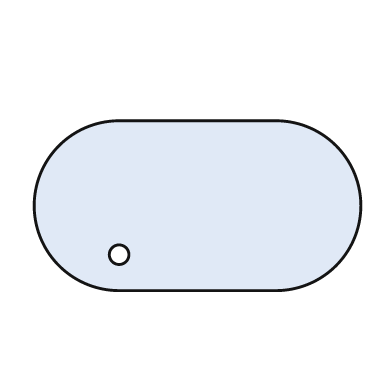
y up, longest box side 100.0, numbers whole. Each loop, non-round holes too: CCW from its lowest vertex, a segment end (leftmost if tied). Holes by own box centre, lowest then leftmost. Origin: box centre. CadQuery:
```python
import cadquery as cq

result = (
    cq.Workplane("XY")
    .moveTo(-24.0, -26.0)
    .lineTo(24.0, -26.0)
    .threePointArc((50.0, 0.0), (24.0, 26.0))
    .lineTo(-24.0, 26.0)
    .threePointArc((-50.0, 0.0), (-24.0, -26.0))
    .close()
    .moveTo(-24.0, -15.0)
    .circle(3.0)
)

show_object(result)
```